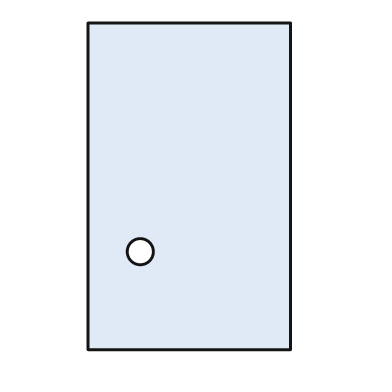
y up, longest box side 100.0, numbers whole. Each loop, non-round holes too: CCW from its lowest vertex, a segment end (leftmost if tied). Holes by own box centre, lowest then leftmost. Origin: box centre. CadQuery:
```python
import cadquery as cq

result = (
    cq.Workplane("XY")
    .moveTo(-31.0, -50.0)
    .lineTo(31.0, -50.0)
    .lineTo(31.0, 50.0)
    .lineTo(-31.0, 50.0)
    .close()
    .moveTo(-15.0, -20.0)
    .circle(4.0)
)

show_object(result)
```